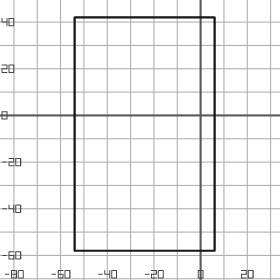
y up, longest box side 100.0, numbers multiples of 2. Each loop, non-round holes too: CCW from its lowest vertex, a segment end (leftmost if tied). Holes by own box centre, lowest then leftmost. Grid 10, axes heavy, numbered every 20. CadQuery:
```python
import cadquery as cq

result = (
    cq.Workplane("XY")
    .moveTo(-54.0, -58.0)
    .lineTo(6.0, -58.0)
    .lineTo(6.0, 42.0)
    .lineTo(-54.0, 42.0)
    .close()
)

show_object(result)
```